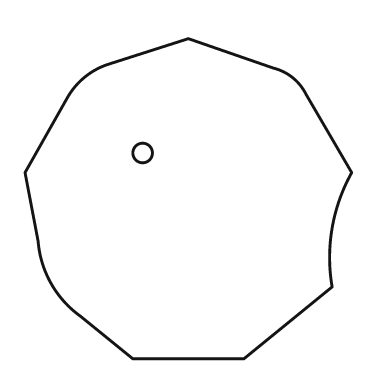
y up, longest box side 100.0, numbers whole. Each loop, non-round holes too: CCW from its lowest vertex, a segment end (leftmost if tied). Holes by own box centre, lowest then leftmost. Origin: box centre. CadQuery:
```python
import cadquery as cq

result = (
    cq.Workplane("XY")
    .moveTo(-17.0, -49.0)
    .lineTo(17.0, -49.0)
    .lineTo(44.0, -27.0)
    .threePointArc((44.0, -9.0), (50.0, 8.0))
    .lineTo(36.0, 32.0)
    .threePointArc((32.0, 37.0), (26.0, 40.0))
    .lineTo(0.0, 49.0)
    .lineTo(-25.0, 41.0)
    .threePointArc((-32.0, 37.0), (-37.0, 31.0))
    .lineTo(-50.0, 8.0)
    .lineTo(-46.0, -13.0)
    .threePointArc((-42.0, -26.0), (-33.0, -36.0))
    .close()
    .moveTo(-14.0, 14.0)
    .circle(3.0)
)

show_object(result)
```